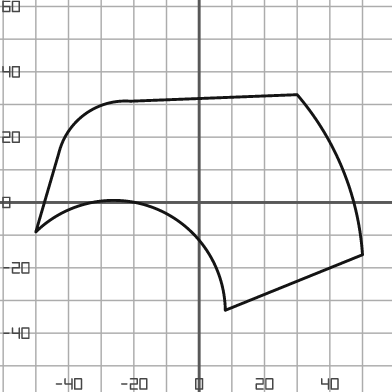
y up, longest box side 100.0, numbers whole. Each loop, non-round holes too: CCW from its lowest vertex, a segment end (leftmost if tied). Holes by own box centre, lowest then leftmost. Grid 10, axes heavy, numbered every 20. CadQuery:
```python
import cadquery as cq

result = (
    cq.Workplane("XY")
    .moveTo(8.0, -33.0)
    .lineTo(50.0, -16.0)
    .threePointArc((44.0, 10.0), (30.0, 33.0))
    .lineTo(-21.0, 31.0)
    .threePointArc((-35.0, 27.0), (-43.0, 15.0))
    .lineTo(-50.0, -9.0)
    .threePointArc((-13.0, -2.0), (8.0, -33.0))
    .close()
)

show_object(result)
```